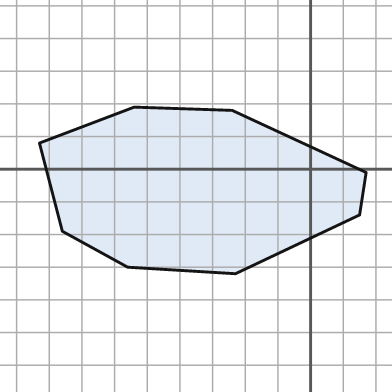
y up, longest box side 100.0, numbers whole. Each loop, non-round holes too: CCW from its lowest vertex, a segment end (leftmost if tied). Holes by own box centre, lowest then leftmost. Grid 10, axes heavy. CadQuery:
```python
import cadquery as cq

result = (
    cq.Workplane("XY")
    .moveTo(-23.0, -32.0)
    .lineTo(15.0, -14.0)
    .lineTo(17.0, -1.0)
    .lineTo(-24.0, 18.0)
    .lineTo(-54.0, 19.0)
    .lineTo(-83.0, 8.0)
    .lineTo(-76.0, -19.0)
    .lineTo(-56.0, -30.0)
    .close()
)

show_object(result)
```